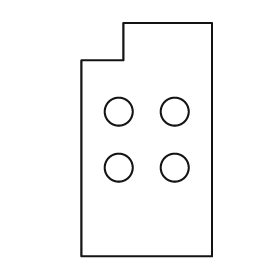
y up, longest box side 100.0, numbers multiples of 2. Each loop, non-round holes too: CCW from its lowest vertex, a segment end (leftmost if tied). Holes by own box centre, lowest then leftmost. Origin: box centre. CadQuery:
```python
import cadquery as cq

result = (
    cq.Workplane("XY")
    .moveTo(-28.0, -50.0)
    .lineTo(28.0, -50.0)
    .lineTo(28.0, 50.0)
    .lineTo(-10.0, 50.0)
    .lineTo(-10.0, 34.0)
    .lineTo(-28.0, 34.0)
    .close()
    .moveTo(-12.0, -12.0)
    .circle(6.0)
    .moveTo(12.0, -12.0)
    .circle(6.0)
    .moveTo(-12.0, 12.0)
    .circle(6.0)
    .moveTo(12.0, 12.0)
    .circle(6.0)
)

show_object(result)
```